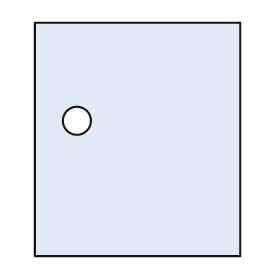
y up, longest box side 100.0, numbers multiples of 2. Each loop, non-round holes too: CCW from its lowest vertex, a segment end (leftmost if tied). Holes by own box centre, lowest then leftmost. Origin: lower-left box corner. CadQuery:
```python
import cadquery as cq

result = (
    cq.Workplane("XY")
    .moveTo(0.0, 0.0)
    .lineTo(88.0, 0.0)
    .lineTo(88.0, 100.0)
    .lineTo(0.0, 100.0)
    .close()
    .moveTo(18.0, 58.0)
    .circle(6.0)
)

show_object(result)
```